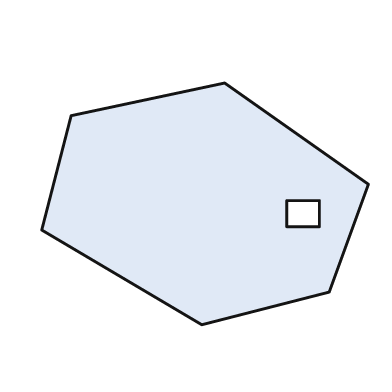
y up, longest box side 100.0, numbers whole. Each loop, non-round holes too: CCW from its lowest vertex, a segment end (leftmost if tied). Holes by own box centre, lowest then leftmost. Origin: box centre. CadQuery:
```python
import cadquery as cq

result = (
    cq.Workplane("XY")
    .moveTo(-1.0, -37.0)
    .lineTo(38.0, -27.0)
    .lineTo(50.0, 6.0)
    .lineTo(6.0, 37.0)
    .lineTo(-41.0, 27.0)
    .lineTo(-50.0, -8.0)
    .close()
    .moveTo(25.0, -7.0)
    .lineTo(35.0, -7.0)
    .lineTo(35.0, 1.0)
    .lineTo(25.0, 1.0)
    .close()
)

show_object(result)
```